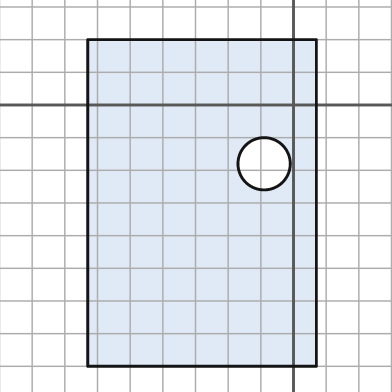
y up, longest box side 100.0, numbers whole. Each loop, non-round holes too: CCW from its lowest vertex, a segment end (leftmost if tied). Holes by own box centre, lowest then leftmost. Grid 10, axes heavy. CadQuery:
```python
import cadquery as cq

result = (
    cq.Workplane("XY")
    .moveTo(-63.0, -80.0)
    .lineTo(7.0, -80.0)
    .lineTo(7.0, 20.0)
    .lineTo(-63.0, 20.0)
    .close()
    .moveTo(-9.0, -18.0)
    .circle(8.0)
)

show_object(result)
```